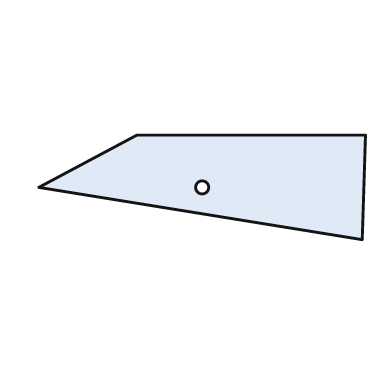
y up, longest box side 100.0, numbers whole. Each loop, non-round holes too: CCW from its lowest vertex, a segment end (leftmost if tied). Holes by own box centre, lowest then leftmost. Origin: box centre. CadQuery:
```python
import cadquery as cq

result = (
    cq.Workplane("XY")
    .moveTo(49.0, -16.0)
    .lineTo(50.0, 16.0)
    .lineTo(-20.0, 16.0)
    .lineTo(-50.0, 0.0)
    .close()
    .moveTo(0.0, 0.0)
    .circle(2.0)
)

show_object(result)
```